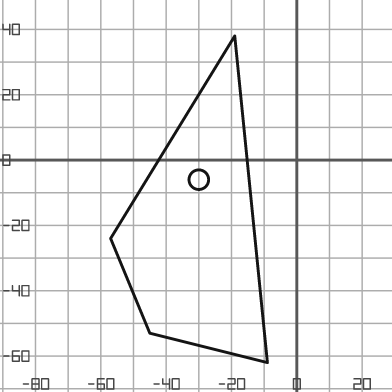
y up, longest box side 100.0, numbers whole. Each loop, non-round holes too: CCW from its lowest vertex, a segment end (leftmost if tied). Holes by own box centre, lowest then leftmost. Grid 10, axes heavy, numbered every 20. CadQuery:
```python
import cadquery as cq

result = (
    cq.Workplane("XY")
    .moveTo(-9.0, -62.0)
    .lineTo(-19.0, 38.0)
    .lineTo(-57.0, -24.0)
    .lineTo(-45.0, -53.0)
    .close()
    .moveTo(-30.0, -6.0)
    .circle(3.0)
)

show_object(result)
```